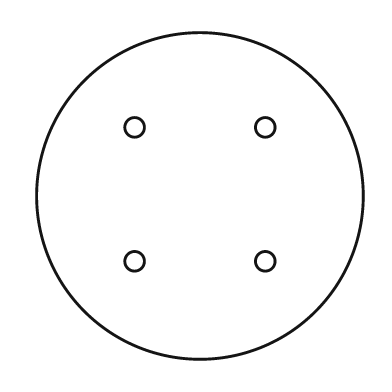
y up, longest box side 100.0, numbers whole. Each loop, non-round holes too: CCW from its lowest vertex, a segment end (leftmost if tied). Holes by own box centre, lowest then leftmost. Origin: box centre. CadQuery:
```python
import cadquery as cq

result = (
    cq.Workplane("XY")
    .moveTo(0.0, 0.0)
    .circle(50.0)
    .moveTo(-20.0, -20.0)
    .circle(3.0)
    .moveTo(20.0, -20.0)
    .circle(3.0)
    .moveTo(-20.0, 21.0)
    .circle(3.0)
    .moveTo(20.0, 21.0)
    .circle(3.0)
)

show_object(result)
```